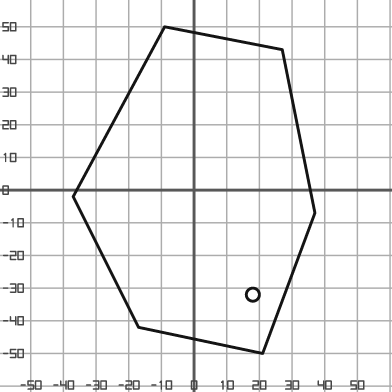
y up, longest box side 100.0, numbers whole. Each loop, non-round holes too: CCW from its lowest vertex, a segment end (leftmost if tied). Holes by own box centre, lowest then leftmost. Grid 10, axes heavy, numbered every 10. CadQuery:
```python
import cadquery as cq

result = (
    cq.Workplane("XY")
    .moveTo(21.0, -50.0)
    .lineTo(37.0, -7.0)
    .lineTo(27.0, 43.0)
    .lineTo(-9.0, 50.0)
    .lineTo(-37.0, -2.0)
    .lineTo(-17.0, -42.0)
    .close()
    .moveTo(18.0, -32.0)
    .circle(2.0)
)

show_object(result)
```